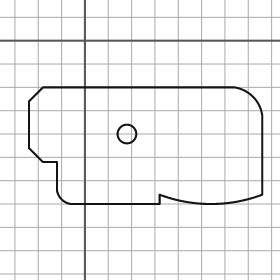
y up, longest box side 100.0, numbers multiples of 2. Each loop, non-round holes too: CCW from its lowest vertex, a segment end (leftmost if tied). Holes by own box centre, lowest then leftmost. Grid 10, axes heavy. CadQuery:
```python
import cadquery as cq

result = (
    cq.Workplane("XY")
    .moveTo(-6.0, -70.0)
    .lineTo(32.0, -70.0)
    .lineTo(32.0, -66.0)
    .threePointArc((54.0, -70.0), (76.0, -66.0))
    .lineTo(76.0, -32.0)
    .threePointArc((72.0, -24.0), (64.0, -20.0))
    .lineTo(-18.0, -20.0)
    .lineTo(-24.0, -26.0)
    .lineTo(-24.0, -46.0)
    .lineTo(-18.0, -52.0)
    .lineTo(-12.0, -52.0)
    .lineTo(-12.0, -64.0)
    .threePointArc((-10.0, -68.0), (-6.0, -70.0))
    .close()
    .moveTo(18.0, -40.0)
    .circle(4.0)
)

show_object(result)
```